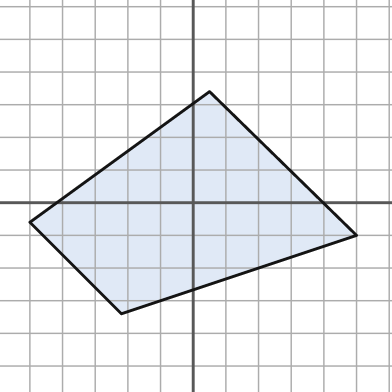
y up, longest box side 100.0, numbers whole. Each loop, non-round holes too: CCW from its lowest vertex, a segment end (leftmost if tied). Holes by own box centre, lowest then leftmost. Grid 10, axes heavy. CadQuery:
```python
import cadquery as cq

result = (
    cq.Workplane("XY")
    .moveTo(-22.0, -34.0)
    .lineTo(50.0, -10.0)
    .lineTo(5.0, 34.0)
    .lineTo(-50.0, -6.0)
    .close()
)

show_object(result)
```